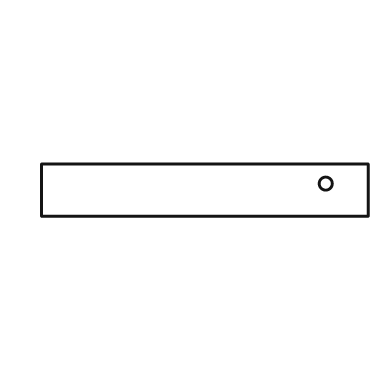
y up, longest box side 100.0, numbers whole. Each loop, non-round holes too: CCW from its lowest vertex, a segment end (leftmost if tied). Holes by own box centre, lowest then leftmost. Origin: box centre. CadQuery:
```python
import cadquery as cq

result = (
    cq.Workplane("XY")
    .moveTo(-50.0, -8.0)
    .lineTo(50.0, -8.0)
    .lineTo(50.0, 8.0)
    .lineTo(-50.0, 8.0)
    .close()
    .moveTo(37.0, 2.0)
    .circle(2.0)
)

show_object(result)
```